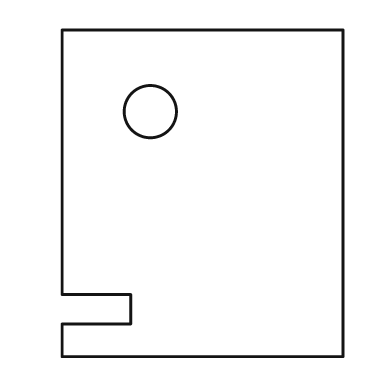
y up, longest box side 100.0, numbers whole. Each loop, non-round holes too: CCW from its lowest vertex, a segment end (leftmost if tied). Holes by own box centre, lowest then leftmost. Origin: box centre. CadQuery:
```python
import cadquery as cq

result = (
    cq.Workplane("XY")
    .moveTo(-43.0, -50.0)
    .lineTo(43.0, -50.0)
    .lineTo(43.0, 50.0)
    .lineTo(-43.0, 50.0)
    .lineTo(-43.0, -31.0)
    .lineTo(-22.0, -31.0)
    .lineTo(-22.0, -40.0)
    .lineTo(-43.0, -40.0)
    .close()
    .moveTo(-16.0, 25.0)
    .circle(8.0)
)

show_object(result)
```